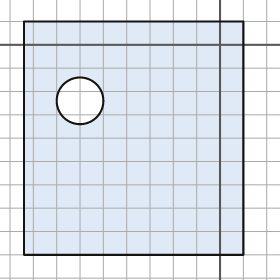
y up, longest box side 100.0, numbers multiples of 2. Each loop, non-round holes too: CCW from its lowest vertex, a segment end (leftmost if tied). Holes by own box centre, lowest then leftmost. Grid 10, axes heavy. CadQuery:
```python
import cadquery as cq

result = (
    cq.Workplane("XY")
    .moveTo(-84.0, -90.0)
    .lineTo(10.0, -90.0)
    .lineTo(10.0, 10.0)
    .lineTo(-84.0, 10.0)
    .close()
    .moveTo(-60.0, -24.0)
    .circle(10.0)
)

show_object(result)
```